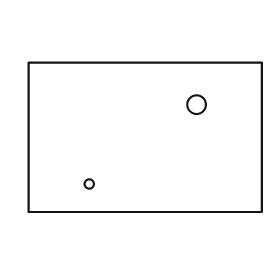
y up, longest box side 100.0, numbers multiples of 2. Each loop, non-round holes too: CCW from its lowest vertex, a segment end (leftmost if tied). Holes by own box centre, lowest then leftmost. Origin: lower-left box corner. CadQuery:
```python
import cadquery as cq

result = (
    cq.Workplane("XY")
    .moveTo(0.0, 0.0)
    .lineTo(100.0, 0.0)
    .lineTo(100.0, 64.0)
    .lineTo(0.0, 64.0)
    .close()
    .moveTo(26.0, 12.0)
    .circle(2.0)
    .moveTo(72.0, 46.0)
    .circle(4.0)
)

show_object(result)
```